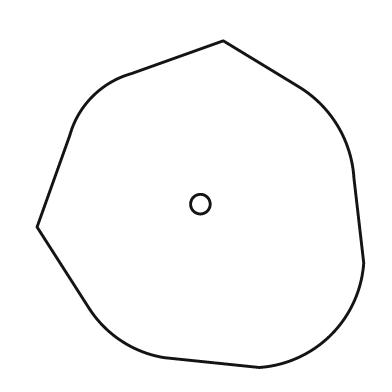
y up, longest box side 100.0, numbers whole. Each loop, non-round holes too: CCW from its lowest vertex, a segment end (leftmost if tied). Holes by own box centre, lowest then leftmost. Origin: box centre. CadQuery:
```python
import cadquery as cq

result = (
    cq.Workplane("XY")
    .moveTo(18.0, -50.0)
    .threePointArc((40.0, -40.0), (50.0, -18.0))
    .lineTo(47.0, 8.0)
    .threePointArc((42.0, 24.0), (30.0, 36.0))
    .lineTo(7.0, 50.0)
    .lineTo(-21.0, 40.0)
    .threePointArc((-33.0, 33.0), (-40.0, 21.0))
    .lineTo(-50.0, -7.0)
    .lineTo(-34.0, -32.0)
    .threePointArc((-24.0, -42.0), (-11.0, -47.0))
    .close()
    .moveTo(0.0, 0.0)
    .circle(3.0)
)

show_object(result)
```